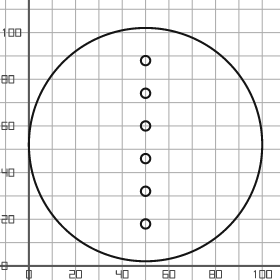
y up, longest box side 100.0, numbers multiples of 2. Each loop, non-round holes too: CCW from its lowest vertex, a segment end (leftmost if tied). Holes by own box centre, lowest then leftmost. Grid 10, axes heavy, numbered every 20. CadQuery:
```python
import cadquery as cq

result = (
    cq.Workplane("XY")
    .moveTo(50.0, 52.0)
    .circle(50.0)
    .moveTo(50.0, 18.0)
    .circle(2.0)
    .moveTo(50.0, 32.0)
    .circle(2.0)
    .moveTo(50.0, 46.0)
    .circle(2.0)
    .moveTo(50.0, 60.0)
    .circle(2.0)
    .moveTo(50.0, 74.0)
    .circle(2.0)
    .moveTo(50.0, 88.0)
    .circle(2.0)
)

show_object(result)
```